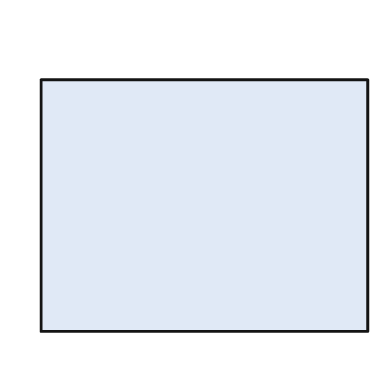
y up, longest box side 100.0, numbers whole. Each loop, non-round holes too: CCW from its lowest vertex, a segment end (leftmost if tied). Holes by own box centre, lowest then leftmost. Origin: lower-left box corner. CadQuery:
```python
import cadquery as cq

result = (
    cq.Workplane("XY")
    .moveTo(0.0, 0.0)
    .lineTo(100.0, 0.0)
    .lineTo(100.0, 77.0)
    .lineTo(0.0, 77.0)
    .close()
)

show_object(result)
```